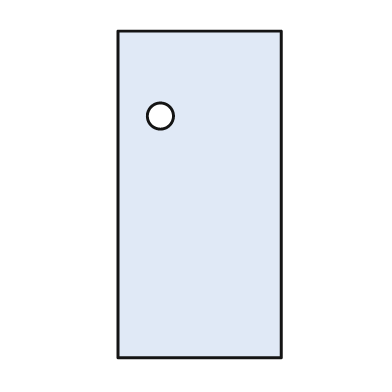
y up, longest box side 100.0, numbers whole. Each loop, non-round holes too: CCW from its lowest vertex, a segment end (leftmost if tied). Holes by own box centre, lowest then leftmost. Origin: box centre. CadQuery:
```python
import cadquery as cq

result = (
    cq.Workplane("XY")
    .moveTo(-25.0, -50.0)
    .lineTo(25.0, -50.0)
    .lineTo(25.0, 50.0)
    .lineTo(-25.0, 50.0)
    .close()
    .moveTo(-12.0, 24.0)
    .circle(4.0)
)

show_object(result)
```